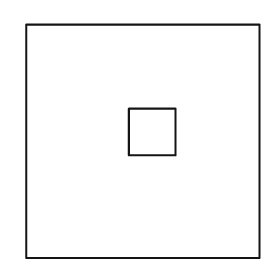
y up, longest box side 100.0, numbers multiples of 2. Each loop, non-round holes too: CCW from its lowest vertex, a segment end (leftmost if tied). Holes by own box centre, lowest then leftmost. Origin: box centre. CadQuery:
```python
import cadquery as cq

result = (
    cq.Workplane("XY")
    .moveTo(-50.0, -50.0)
    .lineTo(50.0, -50.0)
    .lineTo(50.0, 50.0)
    .lineTo(-50.0, 50.0)
    .close()
    .moveTo(-6.0, -6.0)
    .lineTo(14.0, -6.0)
    .lineTo(14.0, 14.0)
    .lineTo(-6.0, 14.0)
    .close()
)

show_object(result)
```